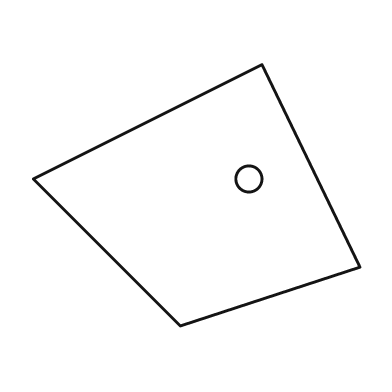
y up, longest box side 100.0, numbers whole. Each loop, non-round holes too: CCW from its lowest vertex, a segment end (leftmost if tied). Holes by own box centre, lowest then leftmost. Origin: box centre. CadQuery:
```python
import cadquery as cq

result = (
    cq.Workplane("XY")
    .moveTo(-5.0, -40.0)
    .lineTo(50.0, -22.0)
    .lineTo(20.0, 40.0)
    .lineTo(-50.0, 5.0)
    .close()
    .moveTo(16.0, 5.0)
    .circle(4.0)
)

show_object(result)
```